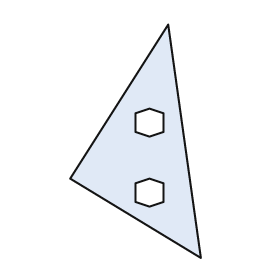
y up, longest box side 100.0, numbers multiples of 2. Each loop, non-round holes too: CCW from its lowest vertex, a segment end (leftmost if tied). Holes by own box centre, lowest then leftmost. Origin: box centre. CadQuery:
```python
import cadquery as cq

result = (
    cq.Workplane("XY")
    .moveTo(28.0, -50.0)
    .lineTo(14.0, 50.0)
    .lineTo(-28.0, -16.0)
    .close()
    .moveTo(6.0, -28.0)
    .lineTo(12.0, -26.0)
    .lineTo(12.0, -18.0)
    .lineTo(6.0, -16.0)
    .lineTo(0.0, -18.0)
    .lineTo(0.0, -26.0)
    .close()
    .moveTo(6.0, 2.0)
    .lineTo(12.0, 4.0)
    .lineTo(12.0, 12.0)
    .lineTo(6.0, 14.0)
    .lineTo(0.0, 12.0)
    .lineTo(0.0, 4.0)
    .close()
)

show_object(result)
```